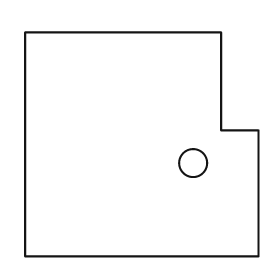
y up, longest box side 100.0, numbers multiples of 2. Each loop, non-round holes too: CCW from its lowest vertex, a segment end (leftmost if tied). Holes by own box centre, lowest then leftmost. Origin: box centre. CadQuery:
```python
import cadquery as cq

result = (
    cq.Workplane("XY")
    .moveTo(-50.0, -48.0)
    .lineTo(50.0, -48.0)
    .lineTo(50.0, 6.0)
    .lineTo(34.0, 6.0)
    .lineTo(34.0, 48.0)
    .lineTo(-50.0, 48.0)
    .close()
    .moveTo(22.0, -8.0)
    .circle(6.0)
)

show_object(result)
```